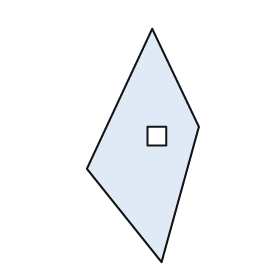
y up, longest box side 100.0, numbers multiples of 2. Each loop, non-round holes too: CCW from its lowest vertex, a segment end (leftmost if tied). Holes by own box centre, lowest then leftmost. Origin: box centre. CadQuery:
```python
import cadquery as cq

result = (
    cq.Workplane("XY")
    .moveTo(8.0, -50.0)
    .lineTo(24.0, 8.0)
    .lineTo(4.0, 50.0)
    .lineTo(-24.0, -10.0)
    .close()
    .moveTo(2.0, 0.0)
    .lineTo(10.0, 0.0)
    .lineTo(10.0, 8.0)
    .lineTo(2.0, 8.0)
    .close()
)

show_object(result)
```